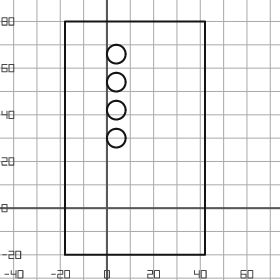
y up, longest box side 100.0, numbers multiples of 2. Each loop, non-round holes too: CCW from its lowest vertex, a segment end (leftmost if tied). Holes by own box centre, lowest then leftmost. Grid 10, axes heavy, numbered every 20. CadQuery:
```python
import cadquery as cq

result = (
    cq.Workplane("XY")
    .moveTo(-18.0, -20.0)
    .lineTo(42.0, -20.0)
    .lineTo(42.0, 80.0)
    .lineTo(-18.0, 80.0)
    .close()
    .moveTo(4.0, 30.0)
    .circle(4.0)
    .moveTo(4.0, 42.0)
    .circle(4.0)
    .moveTo(4.0, 54.0)
    .circle(4.0)
    .moveTo(4.0, 66.0)
    .circle(4.0)
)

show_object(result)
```